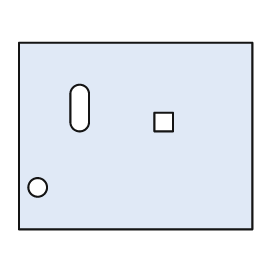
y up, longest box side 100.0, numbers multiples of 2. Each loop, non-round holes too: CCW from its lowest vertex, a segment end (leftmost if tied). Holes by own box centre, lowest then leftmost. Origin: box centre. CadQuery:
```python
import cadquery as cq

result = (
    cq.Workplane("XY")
    .moveTo(-50.0, -40.0)
    .lineTo(50.0, -40.0)
    .lineTo(50.0, 40.0)
    .lineTo(-50.0, 40.0)
    .close()
    .moveTo(-42.0, -22.0)
    .circle(4.0)
    .moveTo(8.0, 2.0)
    .lineTo(16.0, 2.0)
    .lineTo(16.0, 10.0)
    .lineTo(8.0, 10.0)
    .close()
    .moveTo(-28.0, 6.0)
    .threePointArc((-24.0, 2.0), (-20.0, 6.0))
    .lineTo(-20.0, 18.0)
    .threePointArc((-24.0, 22.0), (-28.0, 18.0))
    .close()
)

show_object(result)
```